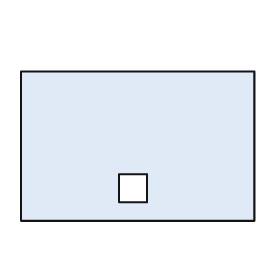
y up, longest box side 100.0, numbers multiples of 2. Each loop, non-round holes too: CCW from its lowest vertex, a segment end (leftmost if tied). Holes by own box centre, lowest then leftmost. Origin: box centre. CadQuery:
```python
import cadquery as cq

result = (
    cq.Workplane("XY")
    .moveTo(-50.0, -32.0)
    .lineTo(50.0, -32.0)
    .lineTo(50.0, 32.0)
    .lineTo(-50.0, 32.0)
    .close()
    .moveTo(-8.0, -24.0)
    .lineTo(4.0, -24.0)
    .lineTo(4.0, -12.0)
    .lineTo(-8.0, -12.0)
    .close()
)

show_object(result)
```